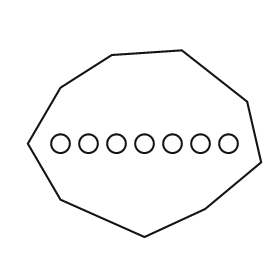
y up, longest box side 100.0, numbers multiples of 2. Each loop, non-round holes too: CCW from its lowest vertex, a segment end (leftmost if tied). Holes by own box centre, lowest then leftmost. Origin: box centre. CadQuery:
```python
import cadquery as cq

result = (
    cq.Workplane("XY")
    .moveTo(0.0, -40.0)
    .lineTo(26.0, -28.0)
    .lineTo(50.0, -8.0)
    .lineTo(44.0, 18.0)
    .lineTo(16.0, 40.0)
    .lineTo(-14.0, 38.0)
    .lineTo(-36.0, 24.0)
    .lineTo(-50.0, 0.0)
    .lineTo(-36.0, -24.0)
    .close()
    .moveTo(-36.0, 0.0)
    .circle(4.0)
    .moveTo(-24.0, 0.0)
    .circle(4.0)
    .moveTo(-12.0, 0.0)
    .circle(4.0)
    .moveTo(0.0, 0.0)
    .circle(4.0)
    .moveTo(12.0, 0.0)
    .circle(4.0)
    .moveTo(24.0, 0.0)
    .circle(4.0)
    .moveTo(36.0, 0.0)
    .circle(4.0)
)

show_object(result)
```